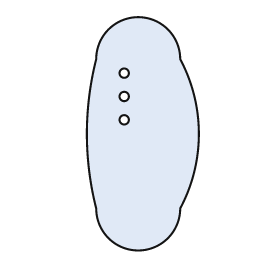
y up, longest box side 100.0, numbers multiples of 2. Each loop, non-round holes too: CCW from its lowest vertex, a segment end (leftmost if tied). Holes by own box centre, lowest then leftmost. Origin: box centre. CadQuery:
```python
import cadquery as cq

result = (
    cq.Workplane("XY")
    .moveTo(-20.0, -32.0)
    .threePointArc((-2.0, -50.0), (16.0, -32.0))
    .threePointArc((24.0, 0.0), (16.0, 32.0))
    .threePointArc((-2.0, 50.0), (-20.0, 32.0))
    .threePointArc((-24.0, 0.0), (-20.0, -32.0))
    .close()
    .moveTo(-8.0, 6.0)
    .circle(2.0)
    .moveTo(-8.0, 16.0)
    .circle(2.0)
    .moveTo(-8.0, 26.0)
    .circle(2.0)
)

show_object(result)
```